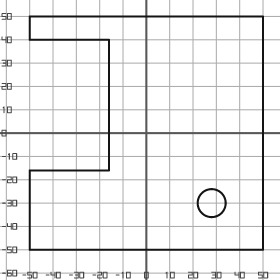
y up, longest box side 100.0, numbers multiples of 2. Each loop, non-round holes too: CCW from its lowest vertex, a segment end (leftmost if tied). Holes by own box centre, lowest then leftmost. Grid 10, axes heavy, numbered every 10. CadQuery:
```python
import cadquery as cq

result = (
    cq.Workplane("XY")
    .moveTo(-50.0, -50.0)
    .lineTo(50.0, -50.0)
    .lineTo(50.0, 50.0)
    .lineTo(-50.0, 50.0)
    .lineTo(-50.0, 40.0)
    .lineTo(-16.0, 40.0)
    .lineTo(-16.0, -16.0)
    .lineTo(-50.0, -16.0)
    .close()
    .moveTo(28.0, -30.0)
    .circle(6.0)
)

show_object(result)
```